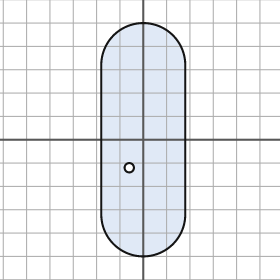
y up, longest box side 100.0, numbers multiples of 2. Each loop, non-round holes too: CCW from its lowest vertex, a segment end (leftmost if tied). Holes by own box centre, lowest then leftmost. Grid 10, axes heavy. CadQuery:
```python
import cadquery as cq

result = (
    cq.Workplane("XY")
    .moveTo(-18.0, -32.0)
    .threePointArc((0.0, -50.0), (18.0, -32.0))
    .lineTo(18.0, 32.0)
    .threePointArc((0.0, 50.0), (-18.0, 32.0))
    .close()
    .moveTo(-6.0, -12.0)
    .circle(2.0)
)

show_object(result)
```